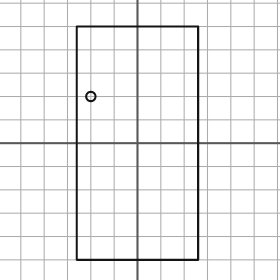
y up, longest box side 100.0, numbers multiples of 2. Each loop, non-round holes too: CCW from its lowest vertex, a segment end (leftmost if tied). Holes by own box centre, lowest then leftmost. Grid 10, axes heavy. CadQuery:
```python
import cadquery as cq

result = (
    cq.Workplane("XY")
    .moveTo(-26.0, -50.0)
    .lineTo(26.0, -50.0)
    .lineTo(26.0, 50.0)
    .lineTo(-26.0, 50.0)
    .close()
    .moveTo(-20.0, 20.0)
    .circle(2.0)
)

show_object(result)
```